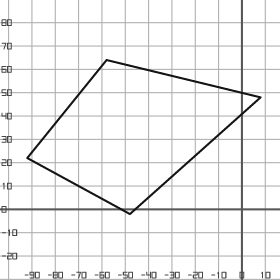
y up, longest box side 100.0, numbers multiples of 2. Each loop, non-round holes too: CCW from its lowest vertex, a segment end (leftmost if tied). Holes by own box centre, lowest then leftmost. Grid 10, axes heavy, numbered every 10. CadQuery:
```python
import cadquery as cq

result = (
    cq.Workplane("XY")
    .moveTo(-48.0, -2.0)
    .lineTo(8.0, 48.0)
    .lineTo(-58.0, 64.0)
    .lineTo(-92.0, 22.0)
    .close()
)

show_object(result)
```